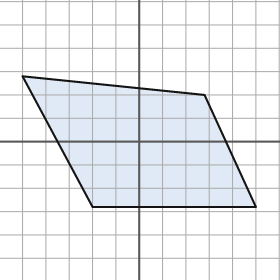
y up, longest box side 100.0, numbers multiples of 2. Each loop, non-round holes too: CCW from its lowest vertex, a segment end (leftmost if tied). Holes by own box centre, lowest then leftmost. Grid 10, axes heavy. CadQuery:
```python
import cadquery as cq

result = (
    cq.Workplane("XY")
    .moveTo(-20.0, -28.0)
    .lineTo(50.0, -28.0)
    .lineTo(28.0, 20.0)
    .lineTo(-50.0, 28.0)
    .close()
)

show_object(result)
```